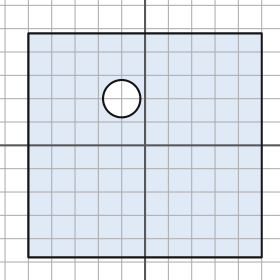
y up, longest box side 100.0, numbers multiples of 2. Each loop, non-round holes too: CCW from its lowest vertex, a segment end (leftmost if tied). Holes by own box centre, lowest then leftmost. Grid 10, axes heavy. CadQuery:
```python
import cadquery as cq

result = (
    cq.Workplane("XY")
    .moveTo(-50.0, -48.0)
    .lineTo(50.0, -48.0)
    .lineTo(50.0, 48.0)
    .lineTo(-50.0, 48.0)
    .close()
    .moveTo(-10.0, 20.0)
    .circle(8.0)
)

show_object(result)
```